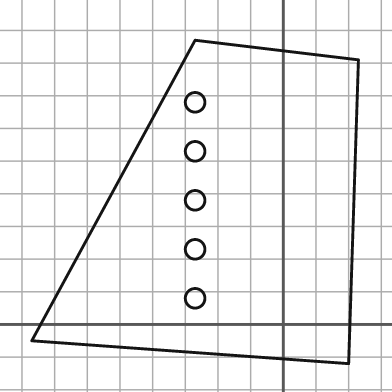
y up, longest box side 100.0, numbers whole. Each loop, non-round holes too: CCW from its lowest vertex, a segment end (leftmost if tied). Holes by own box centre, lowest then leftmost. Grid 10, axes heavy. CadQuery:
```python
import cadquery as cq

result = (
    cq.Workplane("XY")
    .moveTo(20.0, -12.0)
    .lineTo(23.0, 81.0)
    .lineTo(-27.0, 87.0)
    .lineTo(-77.0, -5.0)
    .close()
    .moveTo(-27.0, 8.0)
    .circle(3.0)
    .moveTo(-27.0, 23.0)
    .circle(3.0)
    .moveTo(-27.0, 38.0)
    .circle(3.0)
    .moveTo(-27.0, 53.0)
    .circle(3.0)
    .moveTo(-27.0, 68.0)
    .circle(3.0)
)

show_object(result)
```